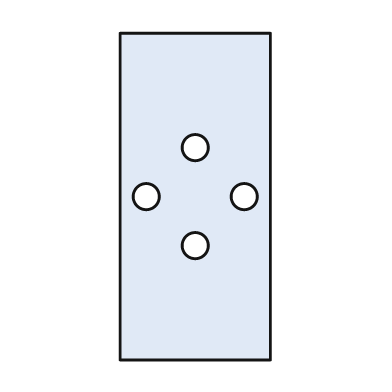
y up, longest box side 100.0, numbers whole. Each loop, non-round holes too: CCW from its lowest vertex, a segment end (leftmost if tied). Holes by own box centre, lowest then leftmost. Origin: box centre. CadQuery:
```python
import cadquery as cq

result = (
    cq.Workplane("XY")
    .moveTo(-23.0, -50.0)
    .lineTo(23.0, -50.0)
    .lineTo(23.0, 50.0)
    .lineTo(-23.0, 50.0)
    .close()
    .moveTo(0.0, -15.0)
    .circle(4.0)
    .moveTo(-15.0, 0.0)
    .circle(4.0)
    .moveTo(15.0, 0.0)
    .circle(4.0)
    .moveTo(0.0, 15.0)
    .circle(4.0)
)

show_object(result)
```